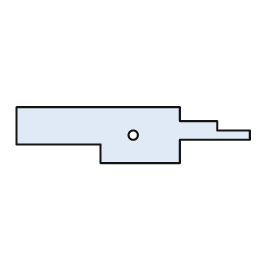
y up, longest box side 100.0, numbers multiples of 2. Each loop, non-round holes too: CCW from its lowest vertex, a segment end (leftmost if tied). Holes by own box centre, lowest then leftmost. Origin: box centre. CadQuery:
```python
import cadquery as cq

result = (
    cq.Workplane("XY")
    .moveTo(-14.0, -12.0)
    .lineTo(20.0, -12.0)
    .lineTo(20.0, -2.0)
    .lineTo(50.0, -2.0)
    .lineTo(50.0, 2.0)
    .lineTo(36.0, 2.0)
    .lineTo(36.0, 6.0)
    .lineTo(20.0, 6.0)
    .lineTo(20.0, 12.0)
    .lineTo(-50.0, 12.0)
    .lineTo(-50.0, -4.0)
    .lineTo(-14.0, -4.0)
    .close()
    .moveTo(0.0, 0.0)
    .circle(2.0)
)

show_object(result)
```